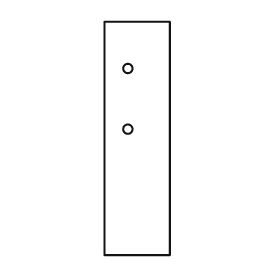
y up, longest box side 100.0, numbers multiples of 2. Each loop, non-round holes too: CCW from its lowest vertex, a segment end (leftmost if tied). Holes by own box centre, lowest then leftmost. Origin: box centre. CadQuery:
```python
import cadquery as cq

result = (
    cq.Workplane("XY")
    .moveTo(-14.0, -50.0)
    .lineTo(14.0, -50.0)
    .lineTo(14.0, 50.0)
    .lineTo(-14.0, 50.0)
    .close()
    .moveTo(-4.0, 4.0)
    .circle(2.0)
    .moveTo(-4.0, 30.0)
    .circle(2.0)
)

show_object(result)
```